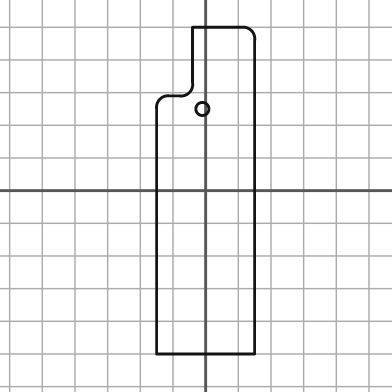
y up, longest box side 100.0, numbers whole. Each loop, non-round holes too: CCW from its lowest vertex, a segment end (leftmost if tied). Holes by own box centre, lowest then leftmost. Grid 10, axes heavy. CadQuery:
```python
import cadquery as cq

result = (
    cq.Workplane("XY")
    .moveTo(-15.0, -50.0)
    .lineTo(15.0, -50.0)
    .lineTo(15.0, 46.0)
    .threePointArc((14.0, 49.0), (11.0, 50.0))
    .lineTo(-4.0, 50.0)
    .lineTo(-4.0, 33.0)
    .threePointArc((-5.0, 30.0), (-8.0, 29.0))
    .lineTo(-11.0, 29.0)
    .threePointArc((-14.0, 28.0), (-15.0, 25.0))
    .close()
    .moveTo(-1.0, 25.0)
    .circle(2.0)
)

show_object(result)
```